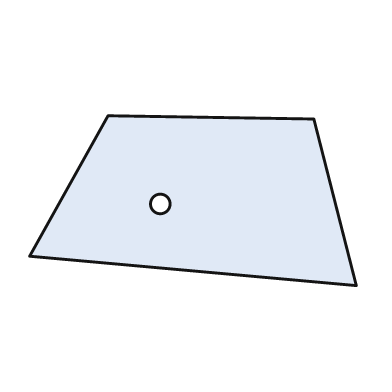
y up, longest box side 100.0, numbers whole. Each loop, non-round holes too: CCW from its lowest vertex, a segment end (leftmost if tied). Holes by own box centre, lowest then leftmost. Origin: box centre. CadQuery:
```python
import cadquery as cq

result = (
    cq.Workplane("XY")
    .moveTo(50.0, -26.0)
    .lineTo(37.0, 25.0)
    .lineTo(-26.0, 26.0)
    .lineTo(-50.0, -17.0)
    .close()
    .moveTo(-10.0, -1.0)
    .circle(3.0)
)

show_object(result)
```